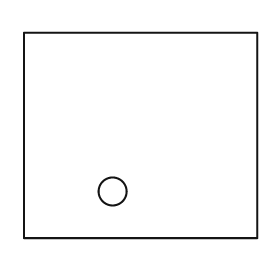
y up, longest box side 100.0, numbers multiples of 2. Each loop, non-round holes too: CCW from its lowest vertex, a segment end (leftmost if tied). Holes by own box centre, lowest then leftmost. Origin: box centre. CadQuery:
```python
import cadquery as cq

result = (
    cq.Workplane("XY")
    .moveTo(-50.0, -44.0)
    .lineTo(50.0, -44.0)
    .lineTo(50.0, 44.0)
    .lineTo(-50.0, 44.0)
    .close()
    .moveTo(-12.0, -24.0)
    .circle(6.0)
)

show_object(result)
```